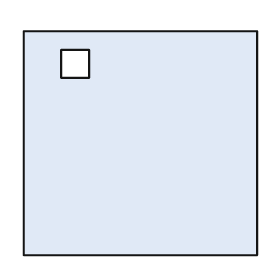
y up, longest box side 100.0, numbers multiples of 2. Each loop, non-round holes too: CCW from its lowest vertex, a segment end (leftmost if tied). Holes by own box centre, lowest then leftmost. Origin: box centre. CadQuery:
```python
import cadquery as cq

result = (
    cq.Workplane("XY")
    .moveTo(-50.0, -48.0)
    .lineTo(50.0, -48.0)
    .lineTo(50.0, 48.0)
    .lineTo(-50.0, 48.0)
    .close()
    .moveTo(-34.0, 28.0)
    .lineTo(-22.0, 28.0)
    .lineTo(-22.0, 40.0)
    .lineTo(-34.0, 40.0)
    .close()
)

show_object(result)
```